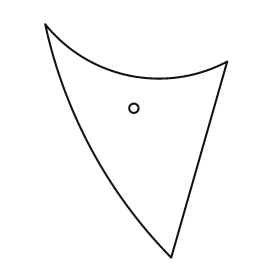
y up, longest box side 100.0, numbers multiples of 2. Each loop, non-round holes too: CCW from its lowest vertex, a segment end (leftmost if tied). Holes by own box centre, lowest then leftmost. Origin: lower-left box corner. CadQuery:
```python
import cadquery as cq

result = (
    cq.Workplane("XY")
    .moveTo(54.0, 0.0)
    .lineTo(78.0, 84.0)
    .threePointArc((36.0, 78.0), (0.0, 100.0))
    .threePointArc((20.0, 46.0), (54.0, 0.0))
    .close()
    .moveTo(38.0, 64.0)
    .circle(2.0)
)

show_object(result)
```